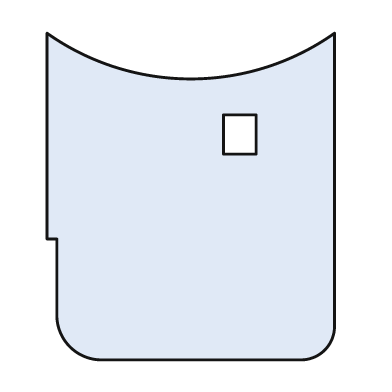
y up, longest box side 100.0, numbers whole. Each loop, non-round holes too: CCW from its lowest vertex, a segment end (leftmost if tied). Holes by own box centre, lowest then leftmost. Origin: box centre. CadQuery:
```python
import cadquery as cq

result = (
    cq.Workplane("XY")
    .moveTo(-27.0, -50.0)
    .lineTo(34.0, -50.0)
    .threePointArc((41.0, -47.0), (44.0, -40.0))
    .lineTo(44.0, 50.0)
    .threePointArc((0.0, 36.0), (-44.0, 50.0))
    .lineTo(-44.0, -13.0)
    .lineTo(-41.0, -13.0)
    .lineTo(-41.0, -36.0)
    .threePointArc((-37.0, -46.0), (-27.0, -50.0))
    .close()
    .moveTo(10.0, 13.0)
    .lineTo(20.0, 13.0)
    .lineTo(20.0, 25.0)
    .lineTo(10.0, 25.0)
    .close()
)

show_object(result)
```